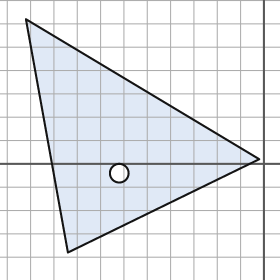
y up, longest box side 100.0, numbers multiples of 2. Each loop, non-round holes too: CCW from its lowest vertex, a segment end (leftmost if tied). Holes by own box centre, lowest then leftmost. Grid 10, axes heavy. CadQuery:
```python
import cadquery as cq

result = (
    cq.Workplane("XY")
    .moveTo(-84.0, -38.0)
    .lineTo(-2.0, 2.0)
    .lineTo(-102.0, 62.0)
    .close()
    .moveTo(-62.0, -4.0)
    .circle(4.0)
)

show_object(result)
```